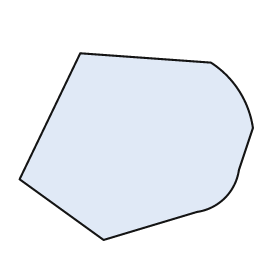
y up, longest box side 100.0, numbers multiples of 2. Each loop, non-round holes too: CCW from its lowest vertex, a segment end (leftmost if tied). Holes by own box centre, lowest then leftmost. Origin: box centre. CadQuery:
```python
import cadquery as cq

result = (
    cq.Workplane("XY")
    .moveTo(-14.0, -40.0)
    .lineTo(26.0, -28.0)
    .threePointArc((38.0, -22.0), (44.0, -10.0))
    .lineTo(50.0, 8.0)
    .threePointArc((44.0, 24.0), (32.0, 36.0))
    .lineTo(-24.0, 40.0)
    .lineTo(-50.0, -14.0)
    .close()
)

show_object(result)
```